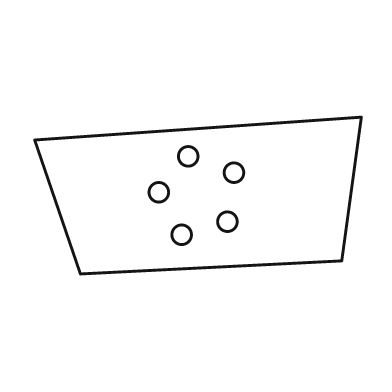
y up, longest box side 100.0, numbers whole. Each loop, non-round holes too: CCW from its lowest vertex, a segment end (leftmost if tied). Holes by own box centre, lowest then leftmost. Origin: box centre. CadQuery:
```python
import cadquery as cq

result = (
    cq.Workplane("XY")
    .moveTo(-36.0, -24.0)
    .lineTo(44.0, -20.0)
    .lineTo(50.0, 24.0)
    .lineTo(-50.0, 17.0)
    .close()
    .moveTo(-5.0, -12.0)
    .circle(3.0)
    .moveTo(9.0, -8.0)
    .circle(3.0)
    .moveTo(-12.0, 1.0)
    .circle(3.0)
    .moveTo(11.0, 7.0)
    .circle(3.0)
    .moveTo(-3.0, 12.0)
    .circle(3.0)
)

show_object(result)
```